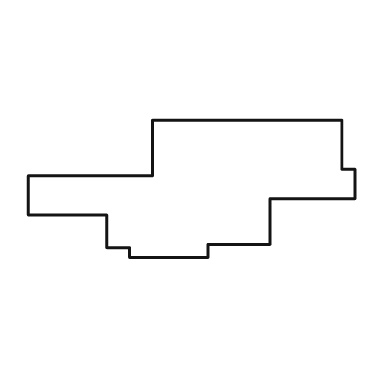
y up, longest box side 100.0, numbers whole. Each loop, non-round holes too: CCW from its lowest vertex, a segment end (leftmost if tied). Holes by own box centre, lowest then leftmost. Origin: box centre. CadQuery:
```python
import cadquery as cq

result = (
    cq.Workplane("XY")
    .moveTo(-19.0, -21.0)
    .lineTo(5.0, -21.0)
    .lineTo(5.0, -17.0)
    .lineTo(24.0, -17.0)
    .lineTo(24.0, -3.0)
    .lineTo(50.0, -3.0)
    .lineTo(50.0, 6.0)
    .lineTo(46.0, 6.0)
    .lineTo(46.0, 21.0)
    .lineTo(-12.0, 21.0)
    .lineTo(-12.0, 4.0)
    .lineTo(-50.0, 4.0)
    .lineTo(-50.0, -8.0)
    .lineTo(-26.0, -8.0)
    .lineTo(-26.0, -18.0)
    .lineTo(-19.0, -18.0)
    .close()
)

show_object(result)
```